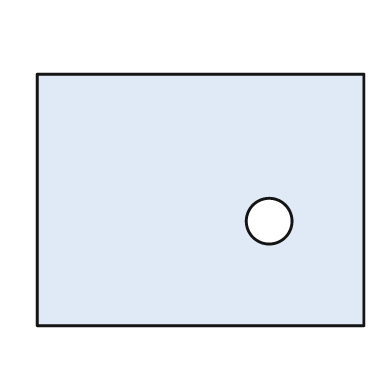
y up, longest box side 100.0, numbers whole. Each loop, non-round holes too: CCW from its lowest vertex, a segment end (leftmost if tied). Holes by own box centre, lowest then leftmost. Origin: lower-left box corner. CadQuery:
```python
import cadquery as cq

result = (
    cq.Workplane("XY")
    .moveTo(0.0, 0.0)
    .lineTo(100.0, 0.0)
    .lineTo(100.0, 77.0)
    .lineTo(0.0, 77.0)
    .close()
    .moveTo(71.0, 32.0)
    .circle(7.0)
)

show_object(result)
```